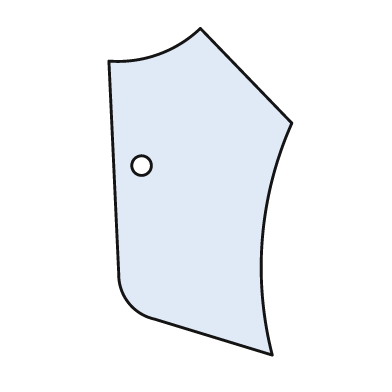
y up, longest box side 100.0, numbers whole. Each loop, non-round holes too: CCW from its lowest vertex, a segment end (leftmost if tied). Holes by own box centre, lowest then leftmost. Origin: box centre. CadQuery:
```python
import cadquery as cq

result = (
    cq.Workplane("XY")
    .moveTo(22.0, -50.0)
    .threePointArc((19.0, -14.0), (28.0, 21.0))
    .lineTo(0.0, 50.0)
    .threePointArc((-13.0, 42.0), (-28.0, 40.0))
    .lineTo(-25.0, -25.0)
    .threePointArc((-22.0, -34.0), (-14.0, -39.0))
    .close()
    .moveTo(-18.0, 8.0)
    .circle(3.0)
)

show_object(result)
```